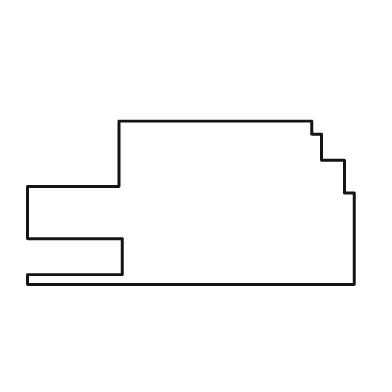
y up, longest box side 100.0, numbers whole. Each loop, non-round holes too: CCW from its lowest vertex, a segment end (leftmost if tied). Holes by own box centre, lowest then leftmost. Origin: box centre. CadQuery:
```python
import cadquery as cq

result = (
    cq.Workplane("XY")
    .moveTo(-50.0, -25.0)
    .lineTo(50.0, -25.0)
    .lineTo(50.0, 3.0)
    .lineTo(47.0, 3.0)
    .lineTo(47.0, 13.0)
    .lineTo(40.0, 13.0)
    .lineTo(40.0, 21.0)
    .lineTo(37.0, 21.0)
    .lineTo(37.0, 25.0)
    .lineTo(-22.0, 25.0)
    .lineTo(-22.0, 5.0)
    .lineTo(-50.0, 5.0)
    .lineTo(-50.0, -11.0)
    .lineTo(-21.0, -11.0)
    .lineTo(-21.0, -22.0)
    .lineTo(-50.0, -22.0)
    .close()
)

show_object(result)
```